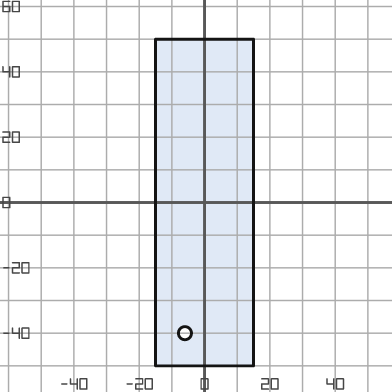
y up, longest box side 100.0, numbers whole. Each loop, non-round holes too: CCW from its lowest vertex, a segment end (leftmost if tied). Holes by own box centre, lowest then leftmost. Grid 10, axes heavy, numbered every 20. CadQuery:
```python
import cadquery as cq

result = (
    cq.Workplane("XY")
    .moveTo(-15.0, -50.0)
    .lineTo(15.0, -50.0)
    .lineTo(15.0, 50.0)
    .lineTo(-15.0, 50.0)
    .close()
    .moveTo(-6.0, -40.0)
    .circle(2.0)
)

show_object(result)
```